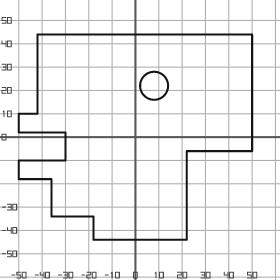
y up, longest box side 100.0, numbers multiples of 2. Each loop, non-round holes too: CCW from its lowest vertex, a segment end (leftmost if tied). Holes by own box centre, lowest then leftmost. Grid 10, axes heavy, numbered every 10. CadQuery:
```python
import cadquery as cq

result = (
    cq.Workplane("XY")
    .moveTo(-18.0, -44.0)
    .lineTo(22.0, -44.0)
    .lineTo(22.0, -6.0)
    .lineTo(50.0, -6.0)
    .lineTo(50.0, 44.0)
    .lineTo(-42.0, 44.0)
    .lineTo(-42.0, 10.0)
    .lineTo(-50.0, 10.0)
    .lineTo(-50.0, 2.0)
    .lineTo(-30.0, 2.0)
    .lineTo(-30.0, -10.0)
    .lineTo(-50.0, -10.0)
    .lineTo(-50.0, -18.0)
    .lineTo(-36.0, -18.0)
    .lineTo(-36.0, -34.0)
    .lineTo(-18.0, -34.0)
    .close()
    .moveTo(8.0, 22.0)
    .circle(6.0)
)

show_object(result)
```